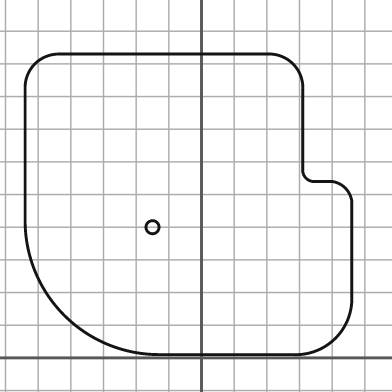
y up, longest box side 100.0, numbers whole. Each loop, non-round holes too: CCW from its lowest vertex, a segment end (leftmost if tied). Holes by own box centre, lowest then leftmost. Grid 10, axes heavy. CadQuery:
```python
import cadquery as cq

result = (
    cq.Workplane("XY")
    .moveTo(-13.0, 1.0)
    .lineTo(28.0, 1.0)
    .threePointArc((41.0, 6.0), (46.0, 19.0))
    .lineTo(46.0, 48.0)
    .threePointArc((44.0, 52.0), (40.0, 54.0))
    .lineTo(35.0, 54.0)
    .threePointArc((32.0, 55.0), (31.0, 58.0))
    .lineTo(31.0, 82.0)
    .threePointArc((28.0, 90.0), (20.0, 93.0))
    .lineTo(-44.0, 93.0)
    .threePointArc((-51.0, 90.0), (-54.0, 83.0))
    .lineTo(-54.0, 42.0)
    .threePointArc((-42.0, 13.0), (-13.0, 1.0))
    .close()
    .moveTo(-15.0, 40.0)
    .circle(2.0)
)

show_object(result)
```